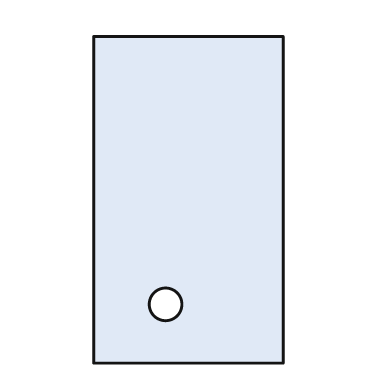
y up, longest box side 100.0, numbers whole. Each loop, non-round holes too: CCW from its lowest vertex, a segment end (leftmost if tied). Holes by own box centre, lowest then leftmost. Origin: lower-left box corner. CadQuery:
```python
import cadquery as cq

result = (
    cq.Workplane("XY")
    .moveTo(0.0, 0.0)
    .lineTo(58.0, 0.0)
    .lineTo(58.0, 100.0)
    .lineTo(0.0, 100.0)
    .close()
    .moveTo(22.0, 18.0)
    .circle(5.0)
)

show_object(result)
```